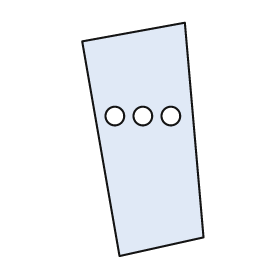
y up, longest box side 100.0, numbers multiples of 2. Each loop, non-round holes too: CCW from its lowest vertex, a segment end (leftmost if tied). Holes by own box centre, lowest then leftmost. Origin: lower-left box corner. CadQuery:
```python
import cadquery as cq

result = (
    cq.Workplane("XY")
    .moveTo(16.0, 0.0)
    .lineTo(52.0, 8.0)
    .lineTo(44.0, 100.0)
    .lineTo(0.0, 92.0)
    .close()
    .moveTo(14.0, 60.0)
    .circle(4.0)
    .moveTo(26.0, 60.0)
    .circle(4.0)
    .moveTo(38.0, 60.0)
    .circle(4.0)
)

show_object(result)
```